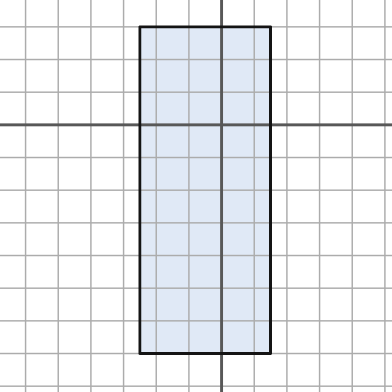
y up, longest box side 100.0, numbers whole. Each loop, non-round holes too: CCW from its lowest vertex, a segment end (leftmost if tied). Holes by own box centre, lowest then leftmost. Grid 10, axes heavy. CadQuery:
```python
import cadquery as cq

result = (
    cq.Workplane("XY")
    .moveTo(-25.0, -70.0)
    .lineTo(15.0, -70.0)
    .lineTo(15.0, 30.0)
    .lineTo(-25.0, 30.0)
    .close()
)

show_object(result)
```